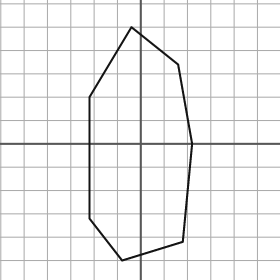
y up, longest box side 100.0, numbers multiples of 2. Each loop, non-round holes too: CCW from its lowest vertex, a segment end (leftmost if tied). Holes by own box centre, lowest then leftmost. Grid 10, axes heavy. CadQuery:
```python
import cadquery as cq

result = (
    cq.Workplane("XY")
    .moveTo(-8.0, -50.0)
    .lineTo(18.0, -42.0)
    .lineTo(22.0, 0.0)
    .lineTo(16.0, 34.0)
    .lineTo(-4.0, 50.0)
    .lineTo(-22.0, 20.0)
    .lineTo(-22.0, -32.0)
    .close()
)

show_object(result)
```